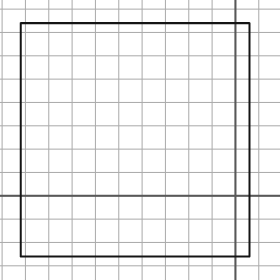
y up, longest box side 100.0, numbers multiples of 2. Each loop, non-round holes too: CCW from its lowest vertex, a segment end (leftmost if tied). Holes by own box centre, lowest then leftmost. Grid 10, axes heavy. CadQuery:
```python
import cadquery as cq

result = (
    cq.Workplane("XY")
    .moveTo(-92.0, -26.0)
    .lineTo(6.0, -26.0)
    .lineTo(6.0, 74.0)
    .lineTo(-92.0, 74.0)
    .close()
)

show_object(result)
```